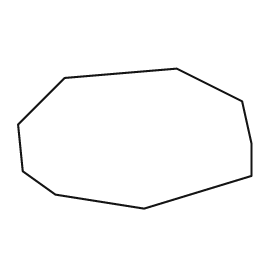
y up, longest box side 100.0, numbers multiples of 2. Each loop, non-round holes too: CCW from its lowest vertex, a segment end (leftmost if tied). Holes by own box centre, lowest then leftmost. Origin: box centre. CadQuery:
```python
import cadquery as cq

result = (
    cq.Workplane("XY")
    .moveTo(4.0, -30.0)
    .lineTo(50.0, -16.0)
    .lineTo(50.0, -2.0)
    .lineTo(46.0, 16.0)
    .lineTo(18.0, 30.0)
    .lineTo(-30.0, 26.0)
    .lineTo(-50.0, 6.0)
    .lineTo(-48.0, -14.0)
    .lineTo(-34.0, -24.0)
    .close()
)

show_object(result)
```